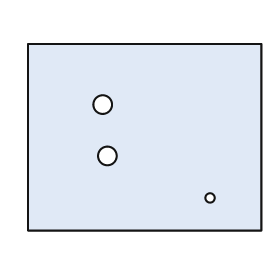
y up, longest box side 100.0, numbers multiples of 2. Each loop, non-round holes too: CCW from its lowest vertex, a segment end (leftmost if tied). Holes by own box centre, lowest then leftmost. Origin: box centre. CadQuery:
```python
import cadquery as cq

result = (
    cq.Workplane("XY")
    .moveTo(-50.0, -40.0)
    .lineTo(50.0, -40.0)
    .lineTo(50.0, 40.0)
    .lineTo(-50.0, 40.0)
    .close()
    .moveTo(28.0, -26.0)
    .circle(2.0)
    .moveTo(-16.0, -8.0)
    .circle(4.0)
    .moveTo(-18.0, 14.0)
    .circle(4.0)
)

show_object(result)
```